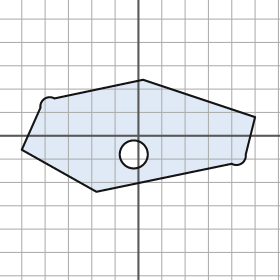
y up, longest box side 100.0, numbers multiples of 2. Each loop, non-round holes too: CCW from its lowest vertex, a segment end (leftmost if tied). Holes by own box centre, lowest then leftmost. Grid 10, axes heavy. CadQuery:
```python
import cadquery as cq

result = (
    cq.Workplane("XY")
    .moveTo(-18.0, -24.0)
    .lineTo(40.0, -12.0)
    .threePointArc((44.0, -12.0), (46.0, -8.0))
    .lineTo(50.0, 8.0)
    .lineTo(2.0, 24.0)
    .lineTo(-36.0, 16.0)
    .threePointArc((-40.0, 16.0), (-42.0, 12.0))
    .lineTo(-50.0, -6.0)
    .close()
    .moveTo(-2.0, -8.0)
    .circle(6.0)
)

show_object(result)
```